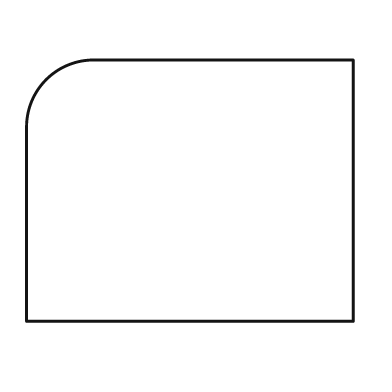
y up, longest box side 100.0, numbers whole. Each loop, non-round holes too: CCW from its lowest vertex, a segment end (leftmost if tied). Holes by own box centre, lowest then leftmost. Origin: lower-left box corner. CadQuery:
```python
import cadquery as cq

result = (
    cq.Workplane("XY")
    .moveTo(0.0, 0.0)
    .lineTo(100.0, 0.0)
    .lineTo(100.0, 80.0)
    .lineTo(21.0, 80.0)
    .threePointArc((6.0, 74.0), (0.0, 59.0))
    .close()
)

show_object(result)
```